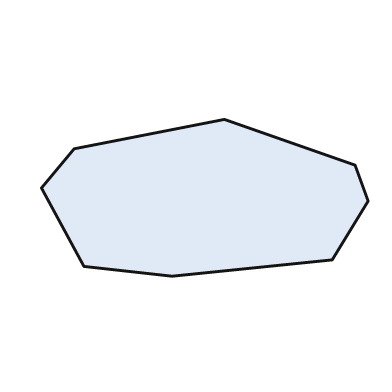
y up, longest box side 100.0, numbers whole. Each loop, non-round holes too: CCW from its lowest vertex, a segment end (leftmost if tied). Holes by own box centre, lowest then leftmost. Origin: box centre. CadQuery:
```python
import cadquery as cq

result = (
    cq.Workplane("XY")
    .moveTo(-10.0, -24.0)
    .lineTo(39.0, -19.0)
    .lineTo(50.0, -1.0)
    .lineTo(46.0, 10.0)
    .lineTo(6.0, 24.0)
    .lineTo(-40.0, 15.0)
    .lineTo(-50.0, 3.0)
    .lineTo(-37.0, -21.0)
    .close()
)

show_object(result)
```